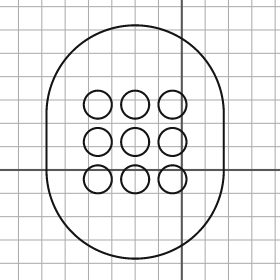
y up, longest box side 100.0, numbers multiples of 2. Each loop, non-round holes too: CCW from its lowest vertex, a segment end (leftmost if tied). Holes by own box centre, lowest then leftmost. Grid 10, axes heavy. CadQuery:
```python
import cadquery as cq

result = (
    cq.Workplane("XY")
    .moveTo(-58.0, 0.0)
    .threePointArc((-20.0, -38.0), (18.0, 0.0))
    .lineTo(18.0, 24.0)
    .threePointArc((-20.0, 62.0), (-58.0, 24.0))
    .close()
    .moveTo(-36.0, -4.0)
    .circle(6.0)
    .moveTo(-20.0, -4.0)
    .circle(6.0)
    .moveTo(-4.0, -4.0)
    .circle(6.0)
    .moveTo(-36.0, 12.0)
    .circle(6.0)
    .moveTo(-20.0, 12.0)
    .circle(6.0)
    .moveTo(-4.0, 12.0)
    .circle(6.0)
    .moveTo(-36.0, 28.0)
    .circle(6.0)
    .moveTo(-20.0, 28.0)
    .circle(6.0)
    .moveTo(-4.0, 28.0)
    .circle(6.0)
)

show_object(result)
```